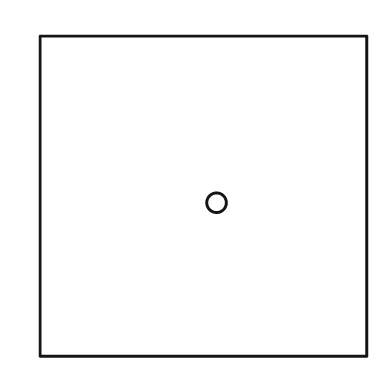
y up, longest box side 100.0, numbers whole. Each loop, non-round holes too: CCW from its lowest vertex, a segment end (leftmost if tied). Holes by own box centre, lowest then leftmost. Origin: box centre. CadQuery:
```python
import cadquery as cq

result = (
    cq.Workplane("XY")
    .moveTo(-50.0, -49.0)
    .lineTo(50.0, -49.0)
    .lineTo(50.0, 49.0)
    .lineTo(-50.0, 49.0)
    .close()
    .moveTo(4.0, -2.0)
    .circle(3.0)
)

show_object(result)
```